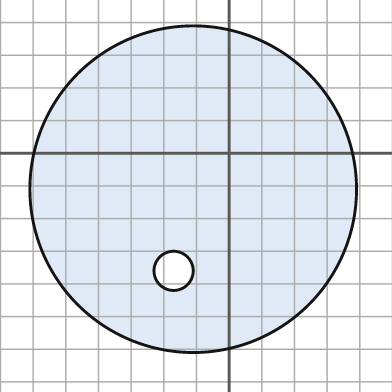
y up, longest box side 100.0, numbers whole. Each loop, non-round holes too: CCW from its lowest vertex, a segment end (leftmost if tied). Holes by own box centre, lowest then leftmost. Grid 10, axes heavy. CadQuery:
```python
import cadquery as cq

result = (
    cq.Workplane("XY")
    .moveTo(-11.0, -11.0)
    .circle(50.0)
    .moveTo(-17.0, -36.0)
    .circle(6.0)
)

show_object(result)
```